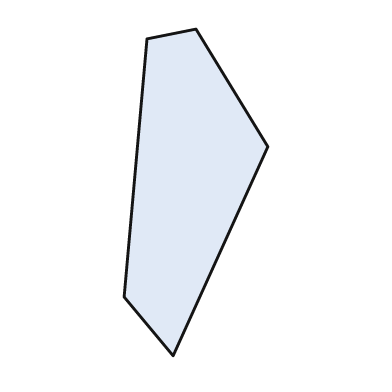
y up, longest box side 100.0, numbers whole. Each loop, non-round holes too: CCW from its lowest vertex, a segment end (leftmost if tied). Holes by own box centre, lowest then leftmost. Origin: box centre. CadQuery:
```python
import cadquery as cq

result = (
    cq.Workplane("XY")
    .moveTo(-7.0, -50.0)
    .lineTo(22.0, 14.0)
    .lineTo(0.0, 50.0)
    .lineTo(-15.0, 47.0)
    .lineTo(-22.0, -32.0)
    .close()
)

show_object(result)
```